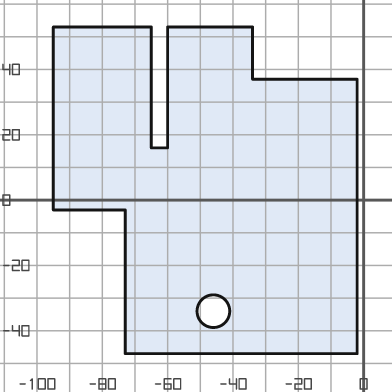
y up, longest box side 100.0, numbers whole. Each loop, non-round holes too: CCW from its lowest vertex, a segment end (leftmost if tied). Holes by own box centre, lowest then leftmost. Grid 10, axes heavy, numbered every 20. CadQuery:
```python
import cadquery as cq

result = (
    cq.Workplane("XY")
    .moveTo(-73.0, -47.0)
    .lineTo(-2.0, -47.0)
    .lineTo(-2.0, 37.0)
    .lineTo(-34.0, 37.0)
    .lineTo(-34.0, 53.0)
    .lineTo(-60.0, 53.0)
    .lineTo(-60.0, 16.0)
    .lineTo(-65.0, 16.0)
    .lineTo(-65.0, 53.0)
    .lineTo(-95.0, 53.0)
    .lineTo(-95.0, -3.0)
    .lineTo(-73.0, -3.0)
    .close()
    .moveTo(-46.0, -34.0)
    .circle(5.0)
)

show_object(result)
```